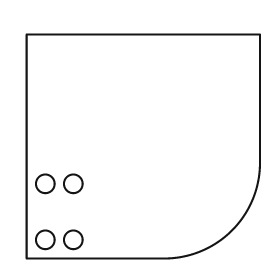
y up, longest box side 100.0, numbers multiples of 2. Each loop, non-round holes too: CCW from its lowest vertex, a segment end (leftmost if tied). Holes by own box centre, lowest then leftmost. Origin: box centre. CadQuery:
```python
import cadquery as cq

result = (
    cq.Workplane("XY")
    .moveTo(-50.0, -48.0)
    .lineTo(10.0, -48.0)
    .threePointArc((38.0, -36.0), (50.0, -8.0))
    .lineTo(50.0, 48.0)
    .lineTo(-50.0, 48.0)
    .close()
    .moveTo(-42.0, -40.0)
    .circle(4.0)
    .moveTo(-30.0, -40.0)
    .circle(4.0)
    .moveTo(-42.0, -16.0)
    .circle(4.0)
    .moveTo(-30.0, -16.0)
    .circle(4.0)
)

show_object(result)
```